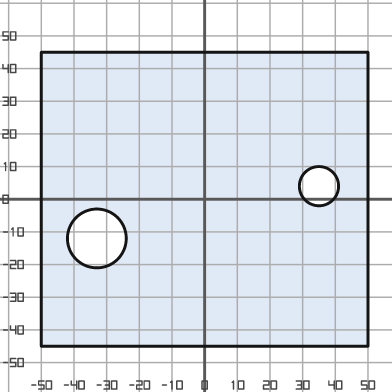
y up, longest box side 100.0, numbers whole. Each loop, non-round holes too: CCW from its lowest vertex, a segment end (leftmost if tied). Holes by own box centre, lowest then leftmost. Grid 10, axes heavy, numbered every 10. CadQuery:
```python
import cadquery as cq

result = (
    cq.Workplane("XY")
    .moveTo(-50.0, -45.0)
    .lineTo(50.0, -45.0)
    .lineTo(50.0, 45.0)
    .lineTo(-50.0, 45.0)
    .close()
    .moveTo(-33.0, -12.0)
    .circle(9.0)
    .moveTo(35.0, 4.0)
    .circle(6.0)
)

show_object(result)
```